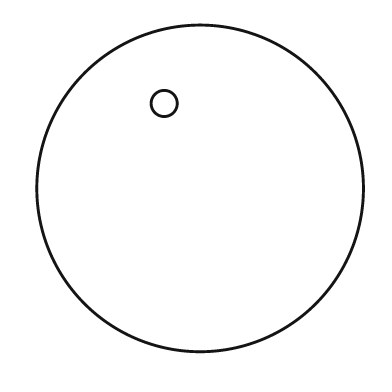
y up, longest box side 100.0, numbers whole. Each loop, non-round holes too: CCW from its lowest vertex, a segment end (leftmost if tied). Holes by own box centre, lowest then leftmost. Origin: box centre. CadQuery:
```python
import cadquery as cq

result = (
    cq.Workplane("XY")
    .moveTo(0.0, 0.0)
    .circle(50.0)
    .moveTo(-11.0, 26.0)
    .circle(4.0)
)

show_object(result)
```